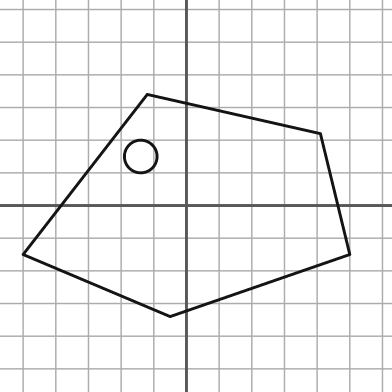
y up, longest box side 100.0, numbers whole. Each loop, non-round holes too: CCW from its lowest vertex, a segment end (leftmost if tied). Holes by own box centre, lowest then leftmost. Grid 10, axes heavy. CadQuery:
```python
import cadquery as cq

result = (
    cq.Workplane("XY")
    .moveTo(-5.0, -34.0)
    .lineTo(50.0, -15.0)
    .lineTo(41.0, 22.0)
    .lineTo(-12.0, 34.0)
    .lineTo(-50.0, -15.0)
    .close()
    .moveTo(-14.0, 15.0)
    .circle(5.0)
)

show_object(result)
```